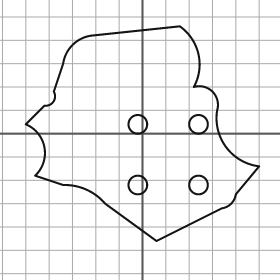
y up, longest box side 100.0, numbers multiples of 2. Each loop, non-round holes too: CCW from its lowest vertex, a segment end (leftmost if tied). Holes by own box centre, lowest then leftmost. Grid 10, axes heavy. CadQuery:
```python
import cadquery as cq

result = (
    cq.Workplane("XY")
    .moveTo(6.0, -46.0)
    .lineTo(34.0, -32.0)
    .threePointArc((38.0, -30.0), (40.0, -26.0))
    .lineTo(50.0, -14.0)
    .threePointArc((36.0, -6.0), (32.0, 10.0))
    .threePointArc((30.0, 18.0), (22.0, 20.0))
    .threePointArc((24.0, 34.0), (16.0, 46.0))
    .lineTo(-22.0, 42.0)
    .threePointArc((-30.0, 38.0), (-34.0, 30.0))
    .lineTo(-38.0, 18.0)
    .threePointArc((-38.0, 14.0), (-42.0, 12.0))
    .lineTo(-50.0, 4.0)
    .threePointArc((-42.0, -6.0), (-46.0, -18.0))
    .lineTo(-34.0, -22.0)
    .threePointArc((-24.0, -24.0), (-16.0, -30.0))
    .close()
    .moveTo(-2.0, -22.0)
    .circle(4.0)
    .moveTo(24.0, -22.0)
    .circle(4.0)
    .moveTo(-2.0, 4.0)
    .circle(4.0)
    .moveTo(24.0, 4.0)
    .circle(4.0)
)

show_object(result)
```